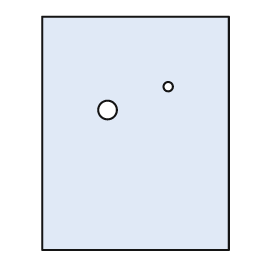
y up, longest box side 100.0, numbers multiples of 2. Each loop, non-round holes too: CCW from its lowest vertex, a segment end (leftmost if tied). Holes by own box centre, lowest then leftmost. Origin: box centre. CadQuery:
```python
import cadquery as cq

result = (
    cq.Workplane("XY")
    .moveTo(-40.0, -50.0)
    .lineTo(40.0, -50.0)
    .lineTo(40.0, 50.0)
    .lineTo(-40.0, 50.0)
    .close()
    .moveTo(-12.0, 10.0)
    .circle(4.0)
    .moveTo(14.0, 20.0)
    .circle(2.0)
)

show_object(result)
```